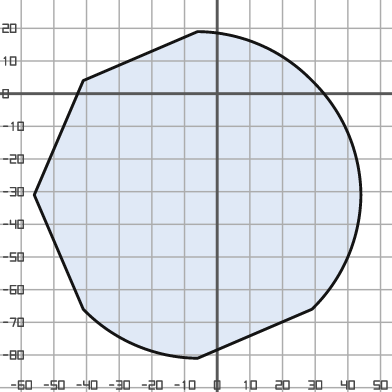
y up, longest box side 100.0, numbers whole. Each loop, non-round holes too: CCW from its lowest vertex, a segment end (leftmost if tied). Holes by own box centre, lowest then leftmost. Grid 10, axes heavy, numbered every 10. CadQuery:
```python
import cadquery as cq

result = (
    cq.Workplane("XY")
    .moveTo(-6.0, -81.0)
    .lineTo(29.0, -66.0)
    .threePointArc((40.0, -50.0), (44.0, -31.0))
    .threePointArc((40.0, -12.0), (29.0, 4.0))
    .threePointArc((13.0, 15.0), (-6.0, 19.0))
    .lineTo(-41.0, 4.0)
    .lineTo(-56.0, -31.0)
    .lineTo(-41.0, -66.0)
    .threePointArc((-25.0, -77.0), (-6.0, -81.0))
    .close()
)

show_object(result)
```